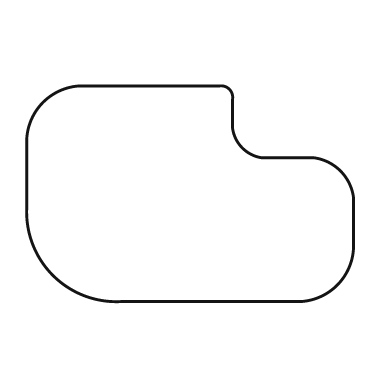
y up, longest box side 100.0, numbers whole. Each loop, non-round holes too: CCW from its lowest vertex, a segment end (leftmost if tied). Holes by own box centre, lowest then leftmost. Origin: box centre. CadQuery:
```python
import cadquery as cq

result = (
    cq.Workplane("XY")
    .moveTo(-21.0, -33.0)
    .lineTo(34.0, -33.0)
    .threePointArc((45.0, -28.0), (50.0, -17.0))
    .lineTo(50.0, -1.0)
    .threePointArc((46.0, 7.0), (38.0, 11.0))
    .lineTo(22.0, 11.0)
    .threePointArc((16.0, 14.0), (13.0, 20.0))
    .lineTo(13.0, 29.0)
    .threePointArc((12.0, 32.0), (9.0, 33.0))
    .lineTo(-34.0, 33.0)
    .threePointArc((-45.0, 28.0), (-50.0, 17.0))
    .lineTo(-50.0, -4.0)
    .threePointArc((-42.0, -25.0), (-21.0, -33.0))
    .close()
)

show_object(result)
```